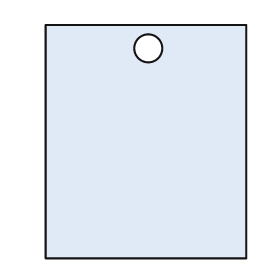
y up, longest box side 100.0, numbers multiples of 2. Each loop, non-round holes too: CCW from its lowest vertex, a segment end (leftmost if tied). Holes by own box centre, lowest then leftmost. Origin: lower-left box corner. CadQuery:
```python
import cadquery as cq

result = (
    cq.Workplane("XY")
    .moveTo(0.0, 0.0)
    .lineTo(86.0, 0.0)
    .lineTo(86.0, 100.0)
    .lineTo(0.0, 100.0)
    .close()
    .moveTo(44.0, 90.0)
    .circle(6.0)
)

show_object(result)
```